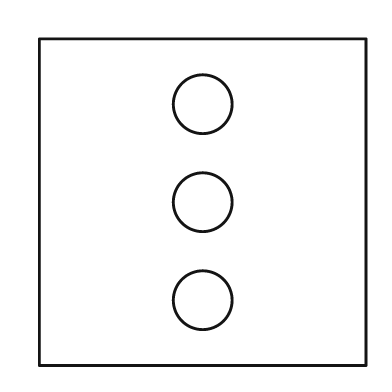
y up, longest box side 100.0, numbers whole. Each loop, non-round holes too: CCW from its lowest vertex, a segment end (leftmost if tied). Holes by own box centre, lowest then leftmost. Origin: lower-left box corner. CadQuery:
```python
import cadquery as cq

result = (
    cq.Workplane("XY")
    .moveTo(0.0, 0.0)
    .lineTo(100.0, 0.0)
    .lineTo(100.0, 100.0)
    .lineTo(0.0, 100.0)
    .close()
    .moveTo(50.0, 20.0)
    .circle(9.0)
    .moveTo(50.0, 50.0)
    .circle(9.0)
    .moveTo(50.0, 80.0)
    .circle(9.0)
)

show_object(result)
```